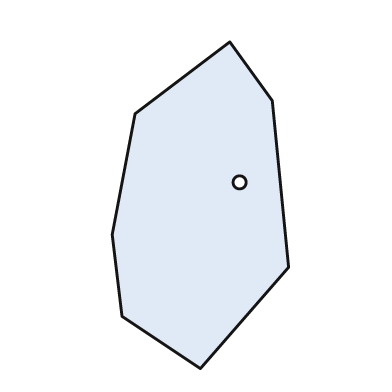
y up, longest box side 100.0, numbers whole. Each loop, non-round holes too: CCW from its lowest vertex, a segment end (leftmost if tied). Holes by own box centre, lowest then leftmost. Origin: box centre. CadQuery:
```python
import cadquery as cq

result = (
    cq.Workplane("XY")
    .moveTo(0.0, -50.0)
    .lineTo(27.0, -19.0)
    .lineTo(22.0, 32.0)
    .lineTo(9.0, 50.0)
    .lineTo(-20.0, 28.0)
    .lineTo(-27.0, -9.0)
    .lineTo(-24.0, -34.0)
    .close()
    .moveTo(12.0, 7.0)
    .circle(2.0)
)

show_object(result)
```